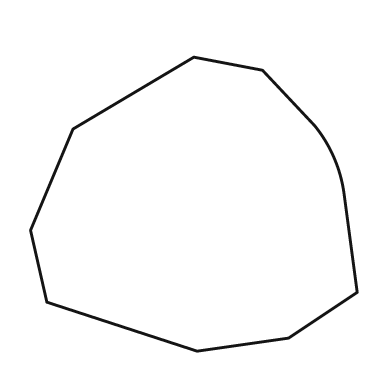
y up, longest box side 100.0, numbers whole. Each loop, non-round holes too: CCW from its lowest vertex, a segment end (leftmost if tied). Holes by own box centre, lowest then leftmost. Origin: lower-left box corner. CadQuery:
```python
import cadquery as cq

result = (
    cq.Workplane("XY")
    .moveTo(51.0, 0.0)
    .lineTo(79.0, 4.0)
    .lineTo(100.0, 18.0)
    .lineTo(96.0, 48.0)
    .threePointArc((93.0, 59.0), (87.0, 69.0))
    .lineTo(71.0, 86.0)
    .lineTo(50.0, 90.0)
    .lineTo(13.0, 68.0)
    .lineTo(0.0, 37.0)
    .lineTo(5.0, 15.0)
    .close()
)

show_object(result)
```